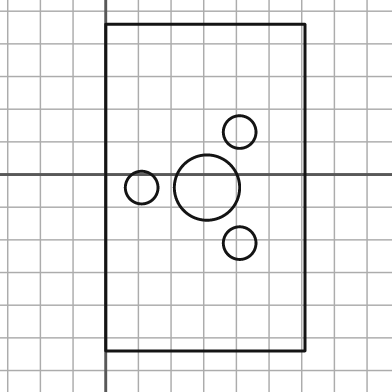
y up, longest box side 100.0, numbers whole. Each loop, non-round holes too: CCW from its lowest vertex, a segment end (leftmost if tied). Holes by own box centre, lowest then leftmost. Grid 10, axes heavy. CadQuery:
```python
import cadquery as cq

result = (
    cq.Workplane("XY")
    .moveTo(0.0, -54.0)
    .lineTo(61.0, -54.0)
    .lineTo(61.0, 46.0)
    .lineTo(0.0, 46.0)
    .close()
    .moveTo(41.0, -21.0)
    .circle(5.0)
    .moveTo(11.0, -4.0)
    .circle(5.0)
    .moveTo(31.0, -4.0)
    .circle(10.0)
    .moveTo(41.0, 13.0)
    .circle(5.0)
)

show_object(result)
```